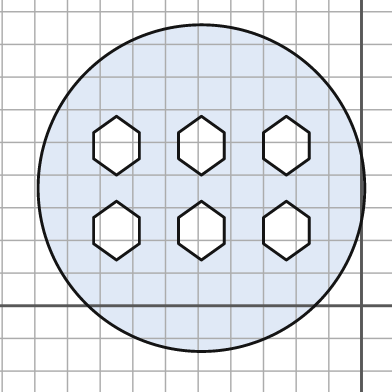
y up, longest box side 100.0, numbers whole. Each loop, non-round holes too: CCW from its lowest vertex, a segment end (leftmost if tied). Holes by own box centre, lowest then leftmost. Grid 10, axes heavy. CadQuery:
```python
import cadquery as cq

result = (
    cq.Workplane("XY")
    .moveTo(-49.0, 36.0)
    .circle(50.0)
    .moveTo(-75.0, 14.0)
    .lineTo(-68.0, 19.0)
    .lineTo(-68.0, 27.0)
    .lineTo(-75.0, 32.0)
    .lineTo(-82.0, 27.0)
    .lineTo(-82.0, 19.0)
    .close()
    .moveTo(-49.0, 14.0)
    .lineTo(-42.0, 19.0)
    .lineTo(-42.0, 27.0)
    .lineTo(-49.0, 32.0)
    .lineTo(-56.0, 27.0)
    .lineTo(-56.0, 19.0)
    .close()
    .moveTo(-23.0, 14.0)
    .lineTo(-16.0, 19.0)
    .lineTo(-16.0, 27.0)
    .lineTo(-23.0, 32.0)
    .lineTo(-30.0, 27.0)
    .lineTo(-30.0, 19.0)
    .close()
    .moveTo(-75.0, 40.0)
    .lineTo(-68.0, 45.0)
    .lineTo(-68.0, 53.0)
    .lineTo(-75.0, 58.0)
    .lineTo(-82.0, 53.0)
    .lineTo(-82.0, 45.0)
    .close()
    .moveTo(-49.0, 40.0)
    .lineTo(-42.0, 45.0)
    .lineTo(-42.0, 53.0)
    .lineTo(-49.0, 58.0)
    .lineTo(-56.0, 53.0)
    .lineTo(-56.0, 45.0)
    .close()
    .moveTo(-23.0, 40.0)
    .lineTo(-16.0, 45.0)
    .lineTo(-16.0, 53.0)
    .lineTo(-23.0, 58.0)
    .lineTo(-30.0, 53.0)
    .lineTo(-30.0, 45.0)
    .close()
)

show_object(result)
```